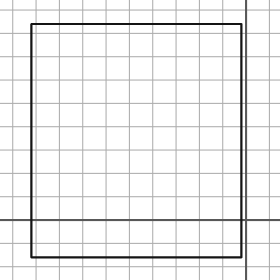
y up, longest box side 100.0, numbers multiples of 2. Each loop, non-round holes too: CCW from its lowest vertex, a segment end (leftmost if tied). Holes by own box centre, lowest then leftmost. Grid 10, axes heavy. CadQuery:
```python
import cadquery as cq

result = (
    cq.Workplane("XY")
    .moveTo(-92.0, -16.0)
    .lineTo(-2.0, -16.0)
    .lineTo(-2.0, 84.0)
    .lineTo(-92.0, 84.0)
    .close()
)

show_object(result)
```